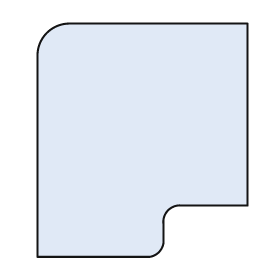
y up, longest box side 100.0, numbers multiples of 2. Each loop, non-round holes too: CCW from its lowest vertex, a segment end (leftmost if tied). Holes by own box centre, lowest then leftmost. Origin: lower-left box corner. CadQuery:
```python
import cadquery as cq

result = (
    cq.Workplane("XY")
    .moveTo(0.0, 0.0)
    .lineTo(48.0, 0.0)
    .threePointArc((52.0, 2.0), (54.0, 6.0))
    .lineTo(54.0, 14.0)
    .threePointArc((56.0, 20.0), (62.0, 22.0))
    .lineTo(90.0, 22.0)
    .lineTo(90.0, 100.0)
    .lineTo(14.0, 100.0)
    .threePointArc((4.0, 96.0), (0.0, 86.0))
    .close()
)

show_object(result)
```